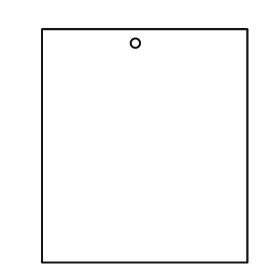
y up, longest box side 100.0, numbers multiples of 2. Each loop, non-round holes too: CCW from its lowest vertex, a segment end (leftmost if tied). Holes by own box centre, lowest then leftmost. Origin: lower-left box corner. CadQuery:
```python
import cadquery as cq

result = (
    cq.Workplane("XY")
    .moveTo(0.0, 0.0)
    .lineTo(88.0, 0.0)
    .lineTo(88.0, 100.0)
    .lineTo(0.0, 100.0)
    .close()
    .moveTo(40.0, 94.0)
    .circle(2.0)
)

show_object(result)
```